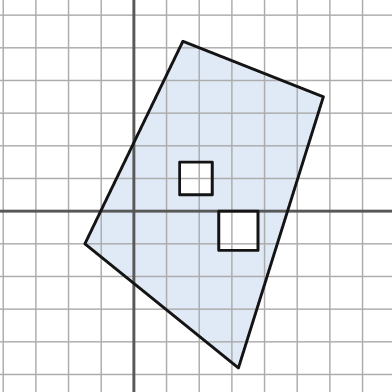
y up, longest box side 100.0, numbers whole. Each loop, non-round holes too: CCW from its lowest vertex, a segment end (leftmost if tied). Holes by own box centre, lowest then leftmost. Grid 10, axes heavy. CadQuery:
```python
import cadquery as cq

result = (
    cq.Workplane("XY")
    .moveTo(32.0, -48.0)
    .lineTo(58.0, 35.0)
    .lineTo(15.0, 52.0)
    .lineTo(-15.0, -10.0)
    .close()
    .moveTo(26.0, -12.0)
    .lineTo(38.0, -12.0)
    .lineTo(38.0, 0.0)
    .lineTo(26.0, 0.0)
    .close()
    .moveTo(14.0, 5.0)
    .lineTo(24.0, 5.0)
    .lineTo(24.0, 15.0)
    .lineTo(14.0, 15.0)
    .close()
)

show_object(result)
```